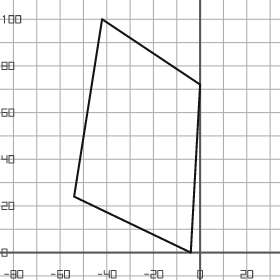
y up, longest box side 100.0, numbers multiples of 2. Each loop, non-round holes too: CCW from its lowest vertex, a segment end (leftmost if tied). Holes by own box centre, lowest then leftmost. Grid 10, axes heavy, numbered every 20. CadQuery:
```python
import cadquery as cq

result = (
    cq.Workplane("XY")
    .moveTo(-4.0, 0.0)
    .lineTo(0.0, 72.0)
    .lineTo(-42.0, 100.0)
    .lineTo(-54.0, 24.0)
    .close()
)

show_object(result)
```